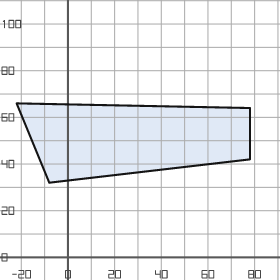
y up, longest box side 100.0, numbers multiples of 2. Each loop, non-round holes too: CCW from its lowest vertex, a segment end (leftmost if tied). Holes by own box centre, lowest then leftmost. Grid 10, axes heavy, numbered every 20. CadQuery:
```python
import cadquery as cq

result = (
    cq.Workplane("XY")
    .moveTo(-8.0, 32.0)
    .lineTo(78.0, 42.0)
    .lineTo(78.0, 64.0)
    .lineTo(-22.0, 66.0)
    .close()
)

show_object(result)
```